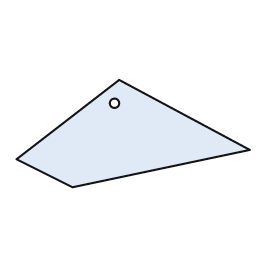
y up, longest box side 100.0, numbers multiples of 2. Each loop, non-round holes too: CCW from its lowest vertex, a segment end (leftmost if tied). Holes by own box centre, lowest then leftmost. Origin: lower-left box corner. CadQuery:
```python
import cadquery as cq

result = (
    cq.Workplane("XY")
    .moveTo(24.0, 0.0)
    .lineTo(100.0, 16.0)
    .lineTo(44.0, 46.0)
    .lineTo(0.0, 12.0)
    .close()
    .moveTo(42.0, 36.0)
    .circle(2.0)
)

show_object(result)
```